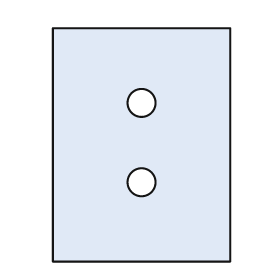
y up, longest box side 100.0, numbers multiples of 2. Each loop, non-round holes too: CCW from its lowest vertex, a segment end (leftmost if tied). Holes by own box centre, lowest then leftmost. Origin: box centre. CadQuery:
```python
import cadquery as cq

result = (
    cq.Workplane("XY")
    .moveTo(-38.0, -50.0)
    .lineTo(38.0, -50.0)
    .lineTo(38.0, 50.0)
    .lineTo(-38.0, 50.0)
    .close()
    .moveTo(0.0, -16.0)
    .circle(6.0)
    .moveTo(0.0, 18.0)
    .circle(6.0)
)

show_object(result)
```